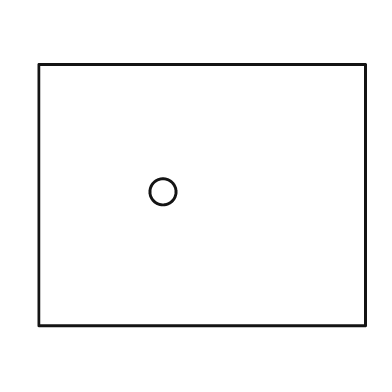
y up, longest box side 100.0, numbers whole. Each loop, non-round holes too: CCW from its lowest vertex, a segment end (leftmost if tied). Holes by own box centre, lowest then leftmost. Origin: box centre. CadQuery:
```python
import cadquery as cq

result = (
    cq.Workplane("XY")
    .moveTo(-50.0, -40.0)
    .lineTo(50.0, -40.0)
    .lineTo(50.0, 40.0)
    .lineTo(-50.0, 40.0)
    .close()
    .moveTo(-12.0, 1.0)
    .circle(4.0)
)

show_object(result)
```